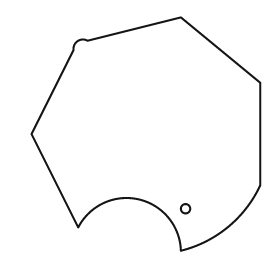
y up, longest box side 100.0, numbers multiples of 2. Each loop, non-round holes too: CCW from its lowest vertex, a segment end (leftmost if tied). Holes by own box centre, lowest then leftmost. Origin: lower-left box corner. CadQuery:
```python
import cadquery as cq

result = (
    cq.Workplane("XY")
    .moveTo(64.0, 0.0)
    .threePointArc((84.0, 10.0), (98.0, 28.0))
    .lineTo(98.0, 72.0)
    .lineTo(64.0, 100.0)
    .lineTo(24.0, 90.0)
    .threePointArc((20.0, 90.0), (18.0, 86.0))
    .lineTo(0.0, 50.0)
    .lineTo(20.0, 10.0)
    .threePointArc((46.0, 22.0), (64.0, 0.0))
    .close()
    .moveTo(66.0, 18.0)
    .circle(2.0)
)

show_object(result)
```